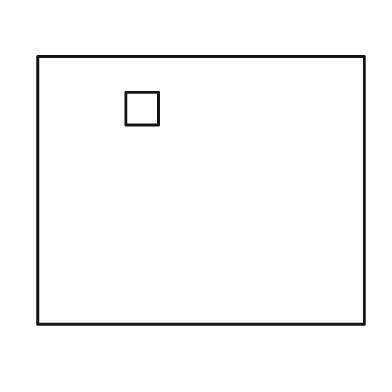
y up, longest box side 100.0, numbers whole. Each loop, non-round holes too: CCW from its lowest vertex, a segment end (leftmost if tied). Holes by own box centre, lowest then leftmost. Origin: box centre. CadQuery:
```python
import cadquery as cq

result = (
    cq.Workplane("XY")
    .moveTo(-50.0, -41.0)
    .lineTo(50.0, -41.0)
    .lineTo(50.0, 41.0)
    .lineTo(-50.0, 41.0)
    .close()
    .moveTo(-23.0, 20.0)
    .lineTo(-13.0, 20.0)
    .lineTo(-13.0, 30.0)
    .lineTo(-23.0, 30.0)
    .close()
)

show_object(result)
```